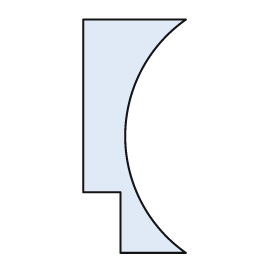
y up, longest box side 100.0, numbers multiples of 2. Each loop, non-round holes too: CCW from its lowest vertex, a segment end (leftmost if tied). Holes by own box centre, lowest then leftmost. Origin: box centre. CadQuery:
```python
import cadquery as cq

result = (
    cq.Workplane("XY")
    .moveTo(-6.0, -50.0)
    .lineTo(22.0, -50.0)
    .threePointArc((-4.0, 0.0), (22.0, 50.0))
    .lineTo(-22.0, 50.0)
    .lineTo(-22.0, -24.0)
    .lineTo(-6.0, -24.0)
    .close()
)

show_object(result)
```